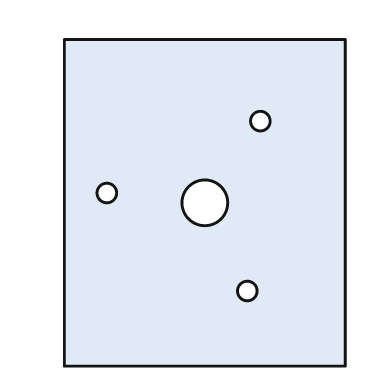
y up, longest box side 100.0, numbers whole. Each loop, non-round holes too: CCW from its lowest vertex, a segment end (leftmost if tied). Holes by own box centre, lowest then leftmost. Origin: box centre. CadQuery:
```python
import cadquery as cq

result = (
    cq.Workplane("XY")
    .moveTo(-43.0, -50.0)
    .lineTo(43.0, -50.0)
    .lineTo(43.0, 50.0)
    .lineTo(-43.0, 50.0)
    .close()
    .moveTo(13.0, -27.0)
    .circle(3.0)
    .moveTo(0.0, 0.0)
    .circle(7.0)
    .moveTo(-30.0, 3.0)
    .circle(3.0)
    .moveTo(17.0, 25.0)
    .circle(3.0)
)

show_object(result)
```